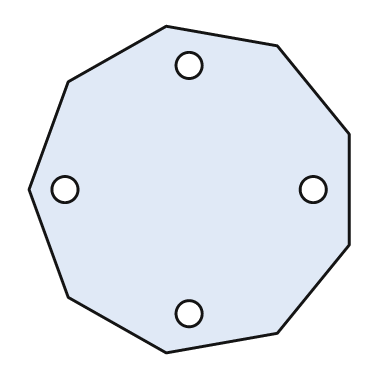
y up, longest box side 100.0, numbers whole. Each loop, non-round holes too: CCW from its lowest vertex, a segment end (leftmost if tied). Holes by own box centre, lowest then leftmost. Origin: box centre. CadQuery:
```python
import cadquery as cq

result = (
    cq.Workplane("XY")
    .moveTo(-7.0, -50.0)
    .lineTo(27.0, -44.0)
    .lineTo(49.0, -17.0)
    .lineTo(49.0, 17.0)
    .lineTo(27.0, 44.0)
    .lineTo(-7.0, 50.0)
    .lineTo(-37.0, 33.0)
    .lineTo(-49.0, 0.0)
    .lineTo(-37.0, -33.0)
    .close()
    .moveTo(0.0, -38.0)
    .circle(4.0)
    .moveTo(-38.0, 0.0)
    .circle(4.0)
    .moveTo(38.0, 0.0)
    .circle(4.0)
    .moveTo(0.0, 38.0)
    .circle(4.0)
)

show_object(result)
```